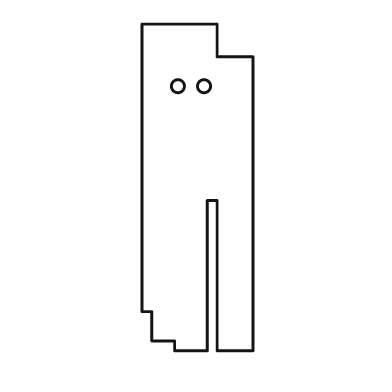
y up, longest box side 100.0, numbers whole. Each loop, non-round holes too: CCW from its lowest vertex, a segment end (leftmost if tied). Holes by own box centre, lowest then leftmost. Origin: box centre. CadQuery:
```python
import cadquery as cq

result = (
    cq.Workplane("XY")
    .moveTo(-7.0, -50.0)
    .lineTo(3.0, -50.0)
    .lineTo(3.0, -4.0)
    .lineTo(6.0, -4.0)
    .lineTo(6.0, -50.0)
    .lineTo(17.0, -50.0)
    .lineTo(17.0, 40.0)
    .lineTo(6.0, 40.0)
    .lineTo(6.0, 50.0)
    .lineTo(-17.0, 50.0)
    .lineTo(-17.0, -38.0)
    .lineTo(-14.0, -38.0)
    .lineTo(-14.0, -47.0)
    .lineTo(-7.0, -47.0)
    .close()
    .moveTo(-6.0, 31.0)
    .circle(2.0)
    .moveTo(2.0, 31.0)
    .circle(2.0)
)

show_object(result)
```